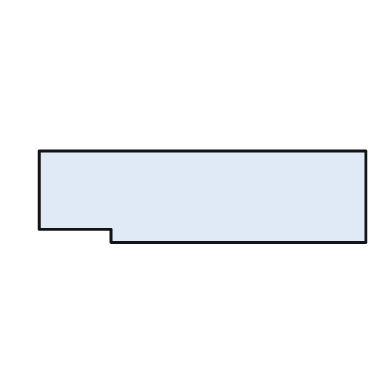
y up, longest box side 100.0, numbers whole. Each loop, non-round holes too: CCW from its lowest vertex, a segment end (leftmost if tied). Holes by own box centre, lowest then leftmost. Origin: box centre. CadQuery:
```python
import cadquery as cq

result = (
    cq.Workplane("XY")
    .moveTo(-28.0, -14.0)
    .lineTo(50.0, -14.0)
    .lineTo(50.0, 14.0)
    .lineTo(-50.0, 14.0)
    .lineTo(-50.0, -10.0)
    .lineTo(-28.0, -10.0)
    .close()
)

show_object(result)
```